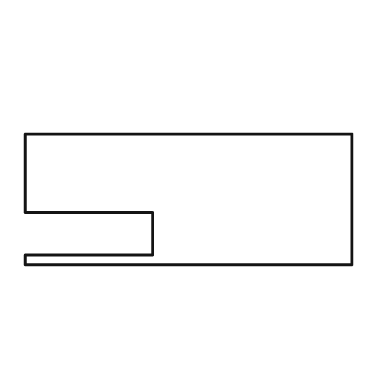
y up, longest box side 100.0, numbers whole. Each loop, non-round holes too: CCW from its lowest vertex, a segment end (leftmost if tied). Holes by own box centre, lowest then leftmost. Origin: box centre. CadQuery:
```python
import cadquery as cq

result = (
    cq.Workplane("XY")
    .moveTo(-50.0, -20.0)
    .lineTo(50.0, -20.0)
    .lineTo(50.0, 20.0)
    .lineTo(-50.0, 20.0)
    .lineTo(-50.0, -4.0)
    .lineTo(-11.0, -4.0)
    .lineTo(-11.0, -17.0)
    .lineTo(-50.0, -17.0)
    .close()
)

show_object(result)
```